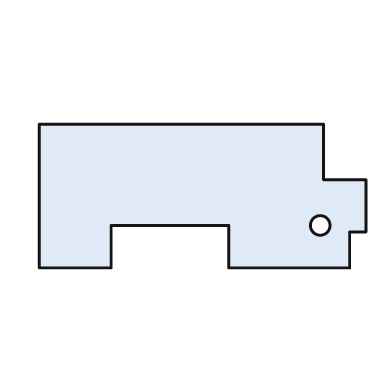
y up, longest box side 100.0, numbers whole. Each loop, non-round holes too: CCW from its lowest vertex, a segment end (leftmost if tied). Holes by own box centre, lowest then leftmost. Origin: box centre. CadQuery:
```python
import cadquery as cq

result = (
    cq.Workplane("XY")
    .moveTo(-50.0, -22.0)
    .lineTo(-28.0, -22.0)
    .lineTo(-28.0, -9.0)
    .lineTo(8.0, -9.0)
    .lineTo(8.0, -22.0)
    .lineTo(45.0, -22.0)
    .lineTo(45.0, -11.0)
    .lineTo(50.0, -11.0)
    .lineTo(50.0, 5.0)
    .lineTo(37.0, 5.0)
    .lineTo(37.0, 22.0)
    .lineTo(-50.0, 22.0)
    .close()
    .moveTo(36.0, -9.0)
    .circle(3.0)
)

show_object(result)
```